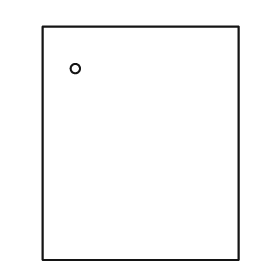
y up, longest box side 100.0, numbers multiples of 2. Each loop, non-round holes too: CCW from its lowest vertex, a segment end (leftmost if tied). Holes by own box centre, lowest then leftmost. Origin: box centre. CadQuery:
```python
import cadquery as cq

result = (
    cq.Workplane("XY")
    .moveTo(-42.0, -50.0)
    .lineTo(42.0, -50.0)
    .lineTo(42.0, 50.0)
    .lineTo(-42.0, 50.0)
    .close()
    .moveTo(-28.0, 32.0)
    .circle(2.0)
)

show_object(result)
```